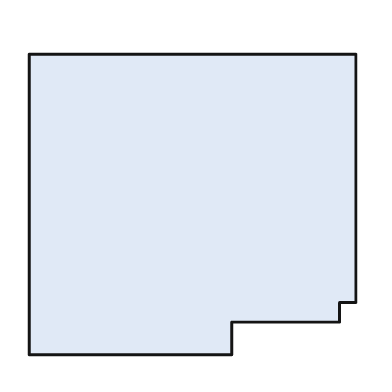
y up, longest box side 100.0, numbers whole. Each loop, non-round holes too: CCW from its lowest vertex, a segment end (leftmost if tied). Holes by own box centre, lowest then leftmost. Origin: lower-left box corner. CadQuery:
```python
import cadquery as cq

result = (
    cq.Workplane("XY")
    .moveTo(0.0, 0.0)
    .lineTo(62.0, 0.0)
    .lineTo(62.0, 10.0)
    .lineTo(95.0, 10.0)
    .lineTo(95.0, 16.0)
    .lineTo(100.0, 16.0)
    .lineTo(100.0, 92.0)
    .lineTo(0.0, 92.0)
    .close()
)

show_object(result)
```